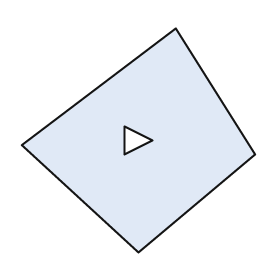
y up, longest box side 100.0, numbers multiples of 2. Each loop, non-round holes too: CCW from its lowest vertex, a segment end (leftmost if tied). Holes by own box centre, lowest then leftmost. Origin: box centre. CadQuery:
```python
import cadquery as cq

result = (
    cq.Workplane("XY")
    .moveTo(0.0, -48.0)
    .lineTo(50.0, -6.0)
    .lineTo(16.0, 48.0)
    .lineTo(-50.0, -2.0)
    .close()
    .moveTo(-6.0, -6.0)
    .lineTo(6.0, 0.0)
    .lineTo(-6.0, 6.0)
    .close()
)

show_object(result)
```